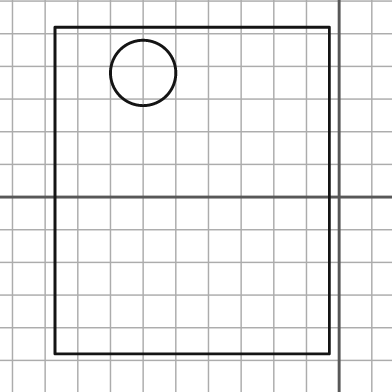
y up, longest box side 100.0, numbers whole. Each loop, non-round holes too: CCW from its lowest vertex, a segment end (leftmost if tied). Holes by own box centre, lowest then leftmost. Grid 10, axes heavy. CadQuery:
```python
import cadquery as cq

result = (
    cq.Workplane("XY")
    .moveTo(-87.0, -48.0)
    .lineTo(-3.0, -48.0)
    .lineTo(-3.0, 52.0)
    .lineTo(-87.0, 52.0)
    .close()
    .moveTo(-60.0, 38.0)
    .circle(10.0)
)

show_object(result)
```